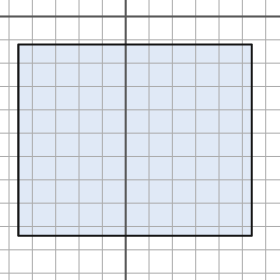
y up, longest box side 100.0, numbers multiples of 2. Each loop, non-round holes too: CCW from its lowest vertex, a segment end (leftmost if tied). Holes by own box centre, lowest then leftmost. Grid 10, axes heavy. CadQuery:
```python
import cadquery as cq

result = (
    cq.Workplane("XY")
    .moveTo(-46.0, -94.0)
    .lineTo(54.0, -94.0)
    .lineTo(54.0, -12.0)
    .lineTo(-46.0, -12.0)
    .close()
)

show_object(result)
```